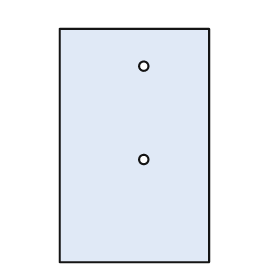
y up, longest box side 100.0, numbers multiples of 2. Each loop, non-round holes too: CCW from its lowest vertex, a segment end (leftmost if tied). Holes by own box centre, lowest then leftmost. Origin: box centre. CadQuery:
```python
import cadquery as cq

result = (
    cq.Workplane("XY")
    .moveTo(-32.0, -50.0)
    .lineTo(32.0, -50.0)
    .lineTo(32.0, 50.0)
    .lineTo(-32.0, 50.0)
    .close()
    .moveTo(4.0, -6.0)
    .circle(2.0)
    .moveTo(4.0, 34.0)
    .circle(2.0)
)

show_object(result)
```